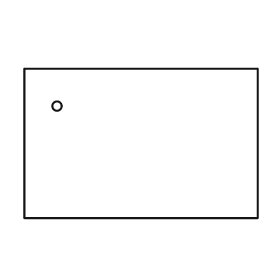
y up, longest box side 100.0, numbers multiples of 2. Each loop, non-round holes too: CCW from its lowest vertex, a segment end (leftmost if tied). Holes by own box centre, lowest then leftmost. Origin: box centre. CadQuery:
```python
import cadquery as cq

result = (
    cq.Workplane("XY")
    .moveTo(-50.0, -32.0)
    .lineTo(50.0, -32.0)
    .lineTo(50.0, 32.0)
    .lineTo(-50.0, 32.0)
    .close()
    .moveTo(-36.0, 16.0)
    .circle(2.0)
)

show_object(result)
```